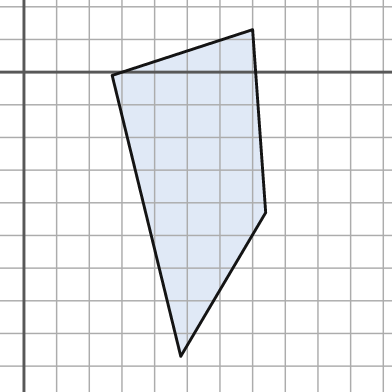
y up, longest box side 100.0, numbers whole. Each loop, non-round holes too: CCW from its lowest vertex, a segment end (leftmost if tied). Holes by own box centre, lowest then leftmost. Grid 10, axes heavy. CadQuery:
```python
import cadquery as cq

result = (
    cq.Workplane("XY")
    .moveTo(48.0, -87.0)
    .lineTo(74.0, -43.0)
    .lineTo(70.0, 13.0)
    .lineTo(27.0, -1.0)
    .close()
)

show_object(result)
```